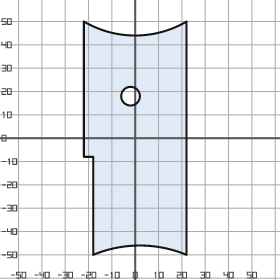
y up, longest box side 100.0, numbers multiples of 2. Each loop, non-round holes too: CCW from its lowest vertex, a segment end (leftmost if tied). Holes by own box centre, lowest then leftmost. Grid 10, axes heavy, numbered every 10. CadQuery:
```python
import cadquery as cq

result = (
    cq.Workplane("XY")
    .moveTo(-18.0, -50.0)
    .threePointArc((2.0, -46.0), (22.0, -50.0))
    .lineTo(22.0, 50.0)
    .threePointArc((0.0, 44.0), (-22.0, 50.0))
    .lineTo(-22.0, -8.0)
    .lineTo(-18.0, -8.0)
    .close()
    .moveTo(-2.0, 18.0)
    .circle(4.0)
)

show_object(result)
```